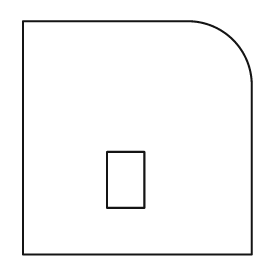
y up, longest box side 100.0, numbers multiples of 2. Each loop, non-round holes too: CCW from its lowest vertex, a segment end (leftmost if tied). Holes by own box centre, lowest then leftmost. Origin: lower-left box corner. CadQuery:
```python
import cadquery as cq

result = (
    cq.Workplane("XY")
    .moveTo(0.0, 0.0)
    .lineTo(98.0, 0.0)
    .lineTo(98.0, 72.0)
    .threePointArc((90.0, 92.0), (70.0, 100.0))
    .lineTo(0.0, 100.0)
    .close()
    .moveTo(36.0, 20.0)
    .lineTo(52.0, 20.0)
    .lineTo(52.0, 44.0)
    .lineTo(36.0, 44.0)
    .close()
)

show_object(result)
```